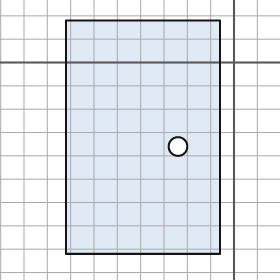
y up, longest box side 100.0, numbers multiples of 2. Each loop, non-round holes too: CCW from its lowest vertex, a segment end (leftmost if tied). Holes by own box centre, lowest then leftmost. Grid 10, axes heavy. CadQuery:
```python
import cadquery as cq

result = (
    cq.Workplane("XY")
    .moveTo(-72.0, -82.0)
    .lineTo(-6.0, -82.0)
    .lineTo(-6.0, 18.0)
    .lineTo(-72.0, 18.0)
    .close()
    .moveTo(-24.0, -36.0)
    .circle(4.0)
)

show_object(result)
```